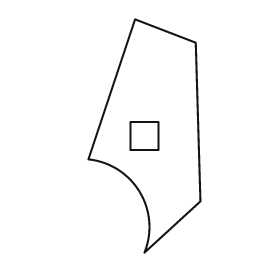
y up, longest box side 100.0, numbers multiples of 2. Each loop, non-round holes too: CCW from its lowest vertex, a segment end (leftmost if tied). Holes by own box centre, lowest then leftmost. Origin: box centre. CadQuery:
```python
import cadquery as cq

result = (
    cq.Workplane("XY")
    .moveTo(0.0, -50.0)
    .lineTo(24.0, -28.0)
    .lineTo(22.0, 40.0)
    .lineTo(-4.0, 50.0)
    .lineTo(-24.0, -10.0)
    .threePointArc((-2.0, -24.0), (0.0, -50.0))
    .close()
    .moveTo(-6.0, -6.0)
    .lineTo(6.0, -6.0)
    .lineTo(6.0, 6.0)
    .lineTo(-6.0, 6.0)
    .close()
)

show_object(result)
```